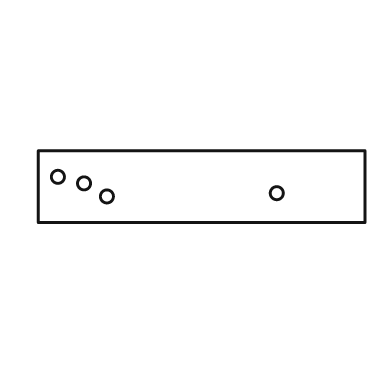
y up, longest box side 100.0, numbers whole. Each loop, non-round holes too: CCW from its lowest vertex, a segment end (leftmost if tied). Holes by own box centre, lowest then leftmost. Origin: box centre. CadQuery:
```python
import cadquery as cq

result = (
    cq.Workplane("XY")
    .moveTo(-50.0, -11.0)
    .lineTo(50.0, -11.0)
    .lineTo(50.0, 11.0)
    .lineTo(-50.0, 11.0)
    .close()
    .moveTo(-29.0, -3.0)
    .circle(2.0)
    .moveTo(23.0, -2.0)
    .circle(2.0)
    .moveTo(-36.0, 1.0)
    .circle(2.0)
    .moveTo(-44.0, 3.0)
    .circle(2.0)
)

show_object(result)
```